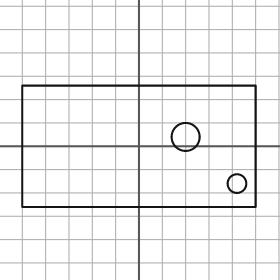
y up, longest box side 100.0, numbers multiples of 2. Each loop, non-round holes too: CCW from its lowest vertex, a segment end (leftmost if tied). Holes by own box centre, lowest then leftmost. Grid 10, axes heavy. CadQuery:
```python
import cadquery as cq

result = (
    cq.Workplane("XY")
    .moveTo(-50.0, -26.0)
    .lineTo(50.0, -26.0)
    .lineTo(50.0, 26.0)
    .lineTo(-50.0, 26.0)
    .close()
    .moveTo(42.0, -16.0)
    .circle(4.0)
    .moveTo(20.0, 4.0)
    .circle(6.0)
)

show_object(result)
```